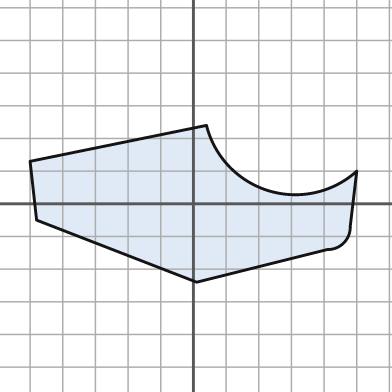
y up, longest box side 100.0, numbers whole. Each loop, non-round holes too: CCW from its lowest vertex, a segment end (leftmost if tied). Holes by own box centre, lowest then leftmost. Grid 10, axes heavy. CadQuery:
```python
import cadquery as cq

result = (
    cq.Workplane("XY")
    .moveTo(1.0, -24.0)
    .lineTo(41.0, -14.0)
    .threePointArc((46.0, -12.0), (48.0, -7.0))
    .lineTo(50.0, 10.0)
    .threePointArc((23.0, 4.0), (4.0, 24.0))
    .lineTo(-50.0, 13.0)
    .lineTo(-48.0, -5.0)
    .close()
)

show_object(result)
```